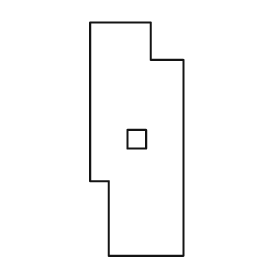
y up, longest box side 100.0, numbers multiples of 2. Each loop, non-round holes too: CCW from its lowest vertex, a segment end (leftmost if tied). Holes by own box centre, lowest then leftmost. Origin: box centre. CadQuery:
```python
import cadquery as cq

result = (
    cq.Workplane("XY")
    .moveTo(-12.0, -50.0)
    .lineTo(20.0, -50.0)
    .lineTo(20.0, 34.0)
    .lineTo(6.0, 34.0)
    .lineTo(6.0, 50.0)
    .lineTo(-20.0, 50.0)
    .lineTo(-20.0, -18.0)
    .lineTo(-12.0, -18.0)
    .close()
    .moveTo(-4.0, -4.0)
    .lineTo(4.0, -4.0)
    .lineTo(4.0, 4.0)
    .lineTo(-4.0, 4.0)
    .close()
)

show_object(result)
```